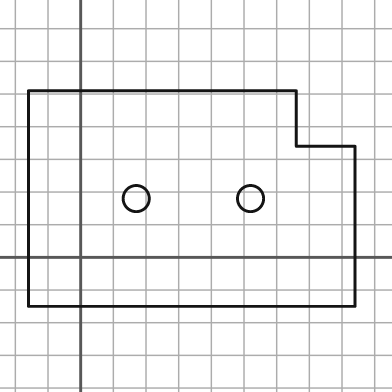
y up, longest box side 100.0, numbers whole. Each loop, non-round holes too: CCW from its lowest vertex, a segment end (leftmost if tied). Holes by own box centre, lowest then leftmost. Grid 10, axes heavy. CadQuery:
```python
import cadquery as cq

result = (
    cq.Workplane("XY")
    .moveTo(-16.0, -15.0)
    .lineTo(84.0, -15.0)
    .lineTo(84.0, 34.0)
    .lineTo(66.0, 34.0)
    .lineTo(66.0, 51.0)
    .lineTo(-16.0, 51.0)
    .close()
    .moveTo(17.0, 18.0)
    .circle(4.0)
    .moveTo(52.0, 18.0)
    .circle(4.0)
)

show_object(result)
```